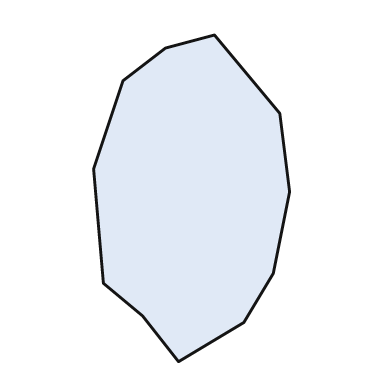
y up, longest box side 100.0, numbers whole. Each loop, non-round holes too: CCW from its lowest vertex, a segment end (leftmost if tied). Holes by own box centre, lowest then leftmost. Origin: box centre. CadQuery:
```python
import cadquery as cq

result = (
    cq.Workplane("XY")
    .moveTo(-4.0, -50.0)
    .lineTo(16.0, -38.0)
    .lineTo(25.0, -23.0)
    .lineTo(30.0, 2.0)
    .lineTo(27.0, 26.0)
    .lineTo(7.0, 50.0)
    .lineTo(-8.0, 46.0)
    .lineTo(-21.0, 36.0)
    .lineTo(-30.0, 9.0)
    .lineTo(-27.0, -26.0)
    .lineTo(-15.0, -36.0)
    .close()
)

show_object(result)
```